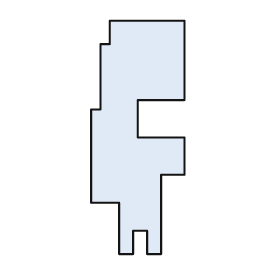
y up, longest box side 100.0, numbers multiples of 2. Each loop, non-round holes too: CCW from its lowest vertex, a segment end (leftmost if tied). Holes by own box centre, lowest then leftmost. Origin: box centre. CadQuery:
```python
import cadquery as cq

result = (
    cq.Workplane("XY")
    .moveTo(-8.0, -50.0)
    .lineTo(-2.0, -50.0)
    .lineTo(-2.0, -40.0)
    .lineTo(4.0, -40.0)
    .lineTo(4.0, -50.0)
    .lineTo(10.0, -50.0)
    .lineTo(10.0, -16.0)
    .lineTo(20.0, -16.0)
    .lineTo(20.0, 0.0)
    .lineTo(0.0, 0.0)
    .lineTo(0.0, 16.0)
    .lineTo(20.0, 16.0)
    .lineTo(20.0, 50.0)
    .lineTo(-12.0, 50.0)
    .lineTo(-12.0, 40.0)
    .lineTo(-16.0, 40.0)
    .lineTo(-16.0, 12.0)
    .lineTo(-20.0, 12.0)
    .lineTo(-20.0, -28.0)
    .lineTo(-8.0, -28.0)
    .close()
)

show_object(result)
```